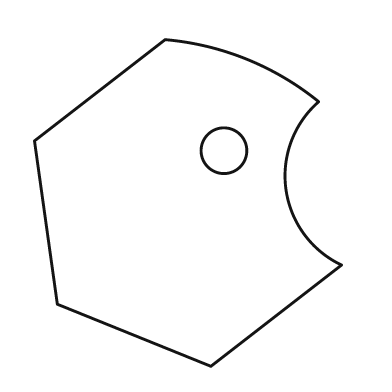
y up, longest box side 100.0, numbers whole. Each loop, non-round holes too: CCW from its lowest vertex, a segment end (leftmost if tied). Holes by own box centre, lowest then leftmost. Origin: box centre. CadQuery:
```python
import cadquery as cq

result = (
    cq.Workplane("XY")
    .moveTo(7.0, -50.0)
    .lineTo(47.0, -19.0)
    .threePointArc((30.0, 4.0), (40.0, 31.0))
    .threePointArc((18.0, 44.0), (-7.0, 50.0))
    .lineTo(-47.0, 19.0)
    .lineTo(-40.0, -31.0)
    .close()
    .moveTo(11.0, 16.0)
    .circle(7.0)
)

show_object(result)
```